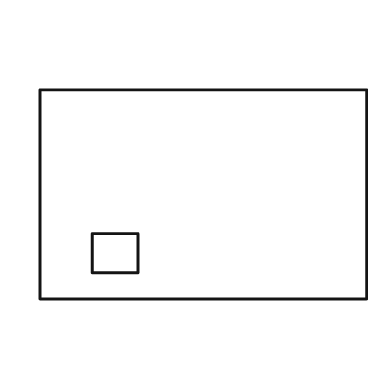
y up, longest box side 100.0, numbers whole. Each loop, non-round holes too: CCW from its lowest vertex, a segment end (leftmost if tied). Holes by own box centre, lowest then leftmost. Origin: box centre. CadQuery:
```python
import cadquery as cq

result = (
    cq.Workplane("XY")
    .moveTo(-50.0, -32.0)
    .lineTo(50.0, -32.0)
    .lineTo(50.0, 32.0)
    .lineTo(-50.0, 32.0)
    .close()
    .moveTo(-34.0, -24.0)
    .lineTo(-20.0, -24.0)
    .lineTo(-20.0, -12.0)
    .lineTo(-34.0, -12.0)
    .close()
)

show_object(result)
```